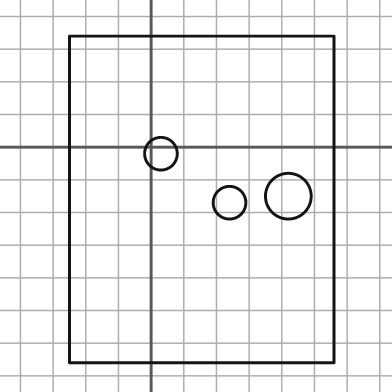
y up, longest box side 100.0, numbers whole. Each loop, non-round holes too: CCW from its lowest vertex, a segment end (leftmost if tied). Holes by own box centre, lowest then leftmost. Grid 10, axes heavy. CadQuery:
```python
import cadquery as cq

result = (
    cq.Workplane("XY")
    .moveTo(-25.0, -66.0)
    .lineTo(56.0, -66.0)
    .lineTo(56.0, 34.0)
    .lineTo(-25.0, 34.0)
    .close()
    .moveTo(24.0, -17.0)
    .circle(5.0)
    .moveTo(42.0, -15.0)
    .circle(7.0)
    .moveTo(3.0, -2.0)
    .circle(5.0)
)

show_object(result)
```